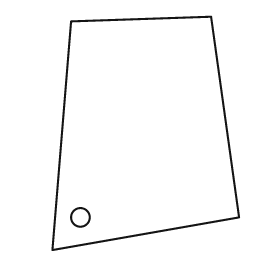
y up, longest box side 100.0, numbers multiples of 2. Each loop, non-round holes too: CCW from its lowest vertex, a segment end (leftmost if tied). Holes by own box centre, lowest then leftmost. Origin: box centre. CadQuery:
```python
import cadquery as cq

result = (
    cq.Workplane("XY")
    .moveTo(-40.0, -50.0)
    .lineTo(40.0, -36.0)
    .lineTo(28.0, 50.0)
    .lineTo(-32.0, 48.0)
    .close()
    .moveTo(-28.0, -36.0)
    .circle(4.0)
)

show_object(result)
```